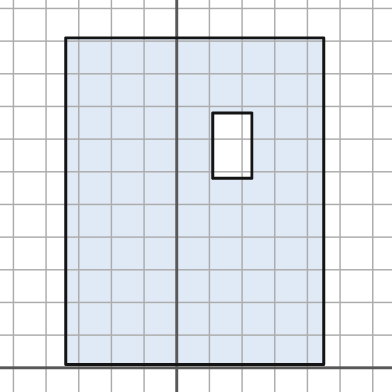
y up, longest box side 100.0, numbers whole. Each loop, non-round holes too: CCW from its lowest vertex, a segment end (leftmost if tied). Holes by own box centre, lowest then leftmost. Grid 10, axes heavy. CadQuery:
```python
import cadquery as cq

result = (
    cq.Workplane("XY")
    .moveTo(-34.0, 1.0)
    .lineTo(45.0, 1.0)
    .lineTo(45.0, 101.0)
    .lineTo(-34.0, 101.0)
    .close()
    .moveTo(11.0, 58.0)
    .lineTo(23.0, 58.0)
    .lineTo(23.0, 78.0)
    .lineTo(11.0, 78.0)
    .close()
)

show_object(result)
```